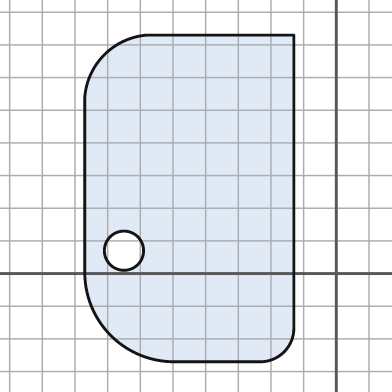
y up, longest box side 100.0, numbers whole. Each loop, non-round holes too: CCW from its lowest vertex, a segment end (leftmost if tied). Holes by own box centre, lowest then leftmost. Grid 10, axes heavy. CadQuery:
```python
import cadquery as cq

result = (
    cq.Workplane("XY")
    .moveTo(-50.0, -27.0)
    .lineTo(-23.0, -27.0)
    .threePointArc((-16.0, -24.0), (-13.0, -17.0))
    .lineTo(-13.0, 73.0)
    .lineTo(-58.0, 73.0)
    .threePointArc((-71.0, 67.0), (-77.0, 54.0))
    .lineTo(-77.0, 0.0)
    .threePointArc((-69.0, -19.0), (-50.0, -27.0))
    .close()
    .moveTo(-65.0, 7.0)
    .circle(6.0)
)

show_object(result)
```